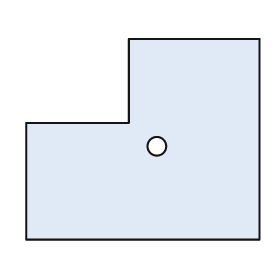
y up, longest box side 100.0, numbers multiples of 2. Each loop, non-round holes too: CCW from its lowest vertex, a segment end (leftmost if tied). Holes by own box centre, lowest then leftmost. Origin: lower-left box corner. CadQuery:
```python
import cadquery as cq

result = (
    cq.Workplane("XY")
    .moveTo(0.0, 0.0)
    .lineTo(100.0, 0.0)
    .lineTo(100.0, 86.0)
    .lineTo(44.0, 86.0)
    .lineTo(44.0, 50.0)
    .lineTo(0.0, 50.0)
    .close()
    .moveTo(56.0, 40.0)
    .circle(4.0)
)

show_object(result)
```